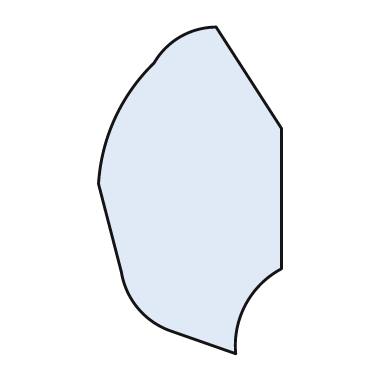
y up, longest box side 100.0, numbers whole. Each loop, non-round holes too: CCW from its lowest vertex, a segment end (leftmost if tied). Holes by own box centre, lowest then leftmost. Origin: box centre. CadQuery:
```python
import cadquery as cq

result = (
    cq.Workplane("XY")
    .moveTo(14.0, -50.0)
    .threePointArc((17.0, -35.0), (28.0, -24.0))
    .lineTo(28.0, 19.0)
    .lineTo(8.0, 50.0)
    .threePointArc((-3.0, 47.0), (-11.0, 39.0))
    .threePointArc((-23.0, 22.0), (-28.0, 2.0))
    .lineTo(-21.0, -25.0)
    .threePointArc((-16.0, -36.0), (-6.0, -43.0))
    .close()
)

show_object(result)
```